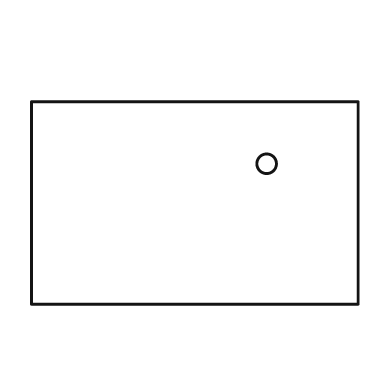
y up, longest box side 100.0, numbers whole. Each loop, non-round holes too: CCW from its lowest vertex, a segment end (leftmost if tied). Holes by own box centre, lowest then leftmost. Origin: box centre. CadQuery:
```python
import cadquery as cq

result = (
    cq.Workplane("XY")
    .moveTo(-50.0, -31.0)
    .lineTo(50.0, -31.0)
    .lineTo(50.0, 31.0)
    .lineTo(-50.0, 31.0)
    .close()
    .moveTo(22.0, 12.0)
    .circle(3.0)
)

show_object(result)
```